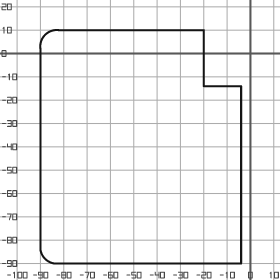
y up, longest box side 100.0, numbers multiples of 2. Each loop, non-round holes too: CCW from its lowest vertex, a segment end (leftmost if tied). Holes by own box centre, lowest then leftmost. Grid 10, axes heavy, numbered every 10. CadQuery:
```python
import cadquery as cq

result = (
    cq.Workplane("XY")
    .moveTo(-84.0, -90.0)
    .lineTo(-4.0, -90.0)
    .lineTo(-4.0, -14.0)
    .lineTo(-20.0, -14.0)
    .lineTo(-20.0, 10.0)
    .lineTo(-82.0, 10.0)
    .threePointArc((-88.0, 8.0), (-90.0, 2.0))
    .lineTo(-90.0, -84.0)
    .threePointArc((-88.0, -88.0), (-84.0, -90.0))
    .close()
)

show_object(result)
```